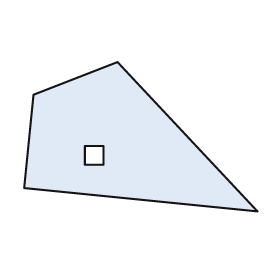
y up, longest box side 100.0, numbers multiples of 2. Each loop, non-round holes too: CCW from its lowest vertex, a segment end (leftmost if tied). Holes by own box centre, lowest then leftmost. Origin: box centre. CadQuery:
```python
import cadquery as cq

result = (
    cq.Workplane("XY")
    .moveTo(50.0, -32.0)
    .lineTo(-10.0, 32.0)
    .lineTo(-46.0, 18.0)
    .lineTo(-50.0, -22.0)
    .close()
    .moveTo(-24.0, -12.0)
    .lineTo(-16.0, -12.0)
    .lineTo(-16.0, -4.0)
    .lineTo(-24.0, -4.0)
    .close()
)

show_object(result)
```